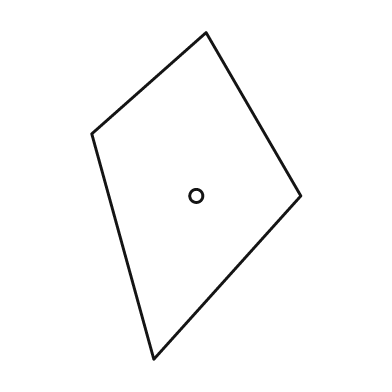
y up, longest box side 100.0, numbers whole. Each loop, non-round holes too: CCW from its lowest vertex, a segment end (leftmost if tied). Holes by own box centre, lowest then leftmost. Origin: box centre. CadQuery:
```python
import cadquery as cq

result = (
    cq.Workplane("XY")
    .moveTo(-13.0, -50.0)
    .lineTo(32.0, 0.0)
    .lineTo(3.0, 50.0)
    .lineTo(-32.0, 19.0)
    .close()
    .moveTo(0.0, 0.0)
    .circle(2.0)
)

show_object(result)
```